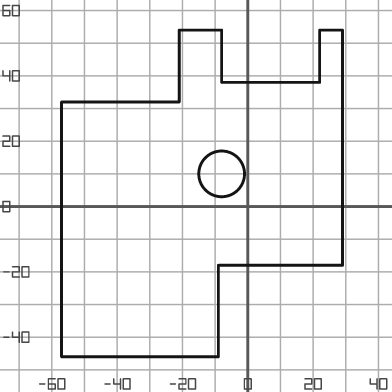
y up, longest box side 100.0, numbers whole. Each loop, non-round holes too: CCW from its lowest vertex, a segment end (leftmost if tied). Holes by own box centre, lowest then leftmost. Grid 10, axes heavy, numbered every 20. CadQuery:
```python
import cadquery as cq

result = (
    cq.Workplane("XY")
    .moveTo(-57.0, -46.0)
    .lineTo(-9.0, -46.0)
    .lineTo(-9.0, -18.0)
    .lineTo(29.0, -18.0)
    .lineTo(29.0, 54.0)
    .lineTo(22.0, 54.0)
    .lineTo(22.0, 38.0)
    .lineTo(-8.0, 38.0)
    .lineTo(-8.0, 54.0)
    .lineTo(-21.0, 54.0)
    .lineTo(-21.0, 32.0)
    .lineTo(-57.0, 32.0)
    .close()
    .moveTo(-8.0, 10.0)
    .circle(7.0)
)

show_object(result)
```